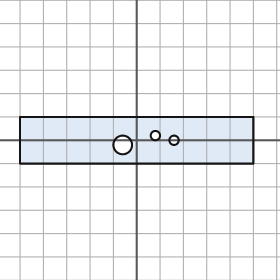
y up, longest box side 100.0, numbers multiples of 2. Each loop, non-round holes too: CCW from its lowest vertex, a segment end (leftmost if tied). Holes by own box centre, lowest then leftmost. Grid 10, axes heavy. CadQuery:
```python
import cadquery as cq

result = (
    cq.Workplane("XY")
    .moveTo(-50.0, -10.0)
    .lineTo(50.0, -10.0)
    .lineTo(50.0, 10.0)
    .lineTo(-50.0, 10.0)
    .close()
    .moveTo(-6.0, -2.0)
    .circle(4.0)
    .moveTo(16.0, 0.0)
    .circle(2.0)
    .moveTo(8.0, 2.0)
    .circle(2.0)
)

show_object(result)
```